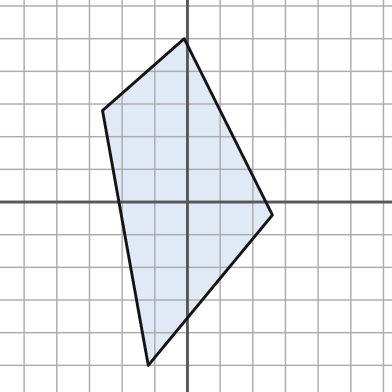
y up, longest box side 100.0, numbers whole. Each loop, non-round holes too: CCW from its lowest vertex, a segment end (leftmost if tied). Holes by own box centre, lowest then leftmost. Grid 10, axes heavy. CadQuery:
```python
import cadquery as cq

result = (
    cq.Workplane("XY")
    .moveTo(-12.0, -50.0)
    .lineTo(26.0, -4.0)
    .lineTo(-1.0, 50.0)
    .lineTo(-26.0, 28.0)
    .close()
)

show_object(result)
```